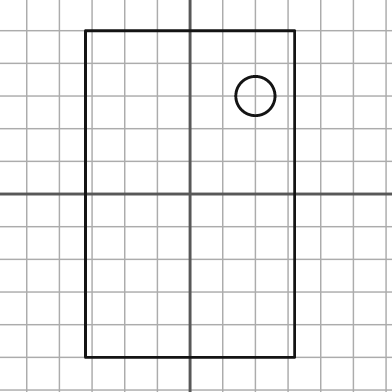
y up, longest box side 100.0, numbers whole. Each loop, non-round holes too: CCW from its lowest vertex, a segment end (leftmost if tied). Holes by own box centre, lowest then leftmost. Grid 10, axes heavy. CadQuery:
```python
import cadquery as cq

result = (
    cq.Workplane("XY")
    .moveTo(-32.0, -50.0)
    .lineTo(32.0, -50.0)
    .lineTo(32.0, 50.0)
    .lineTo(-32.0, 50.0)
    .close()
    .moveTo(20.0, 30.0)
    .circle(6.0)
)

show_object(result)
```